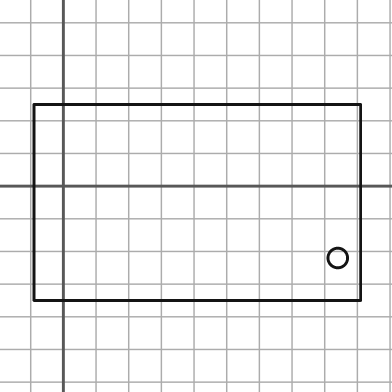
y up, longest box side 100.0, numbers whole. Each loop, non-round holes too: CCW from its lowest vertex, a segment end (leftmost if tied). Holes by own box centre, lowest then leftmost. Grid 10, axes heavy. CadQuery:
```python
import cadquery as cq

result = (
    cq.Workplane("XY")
    .moveTo(-9.0, -35.0)
    .lineTo(91.0, -35.0)
    .lineTo(91.0, 25.0)
    .lineTo(-9.0, 25.0)
    .close()
    .moveTo(84.0, -22.0)
    .circle(3.0)
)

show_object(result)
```